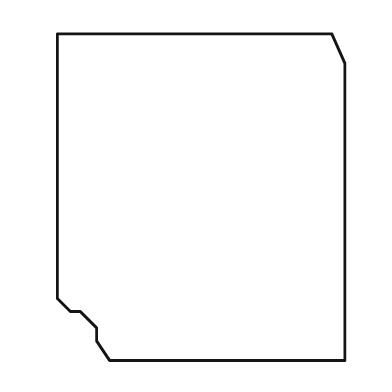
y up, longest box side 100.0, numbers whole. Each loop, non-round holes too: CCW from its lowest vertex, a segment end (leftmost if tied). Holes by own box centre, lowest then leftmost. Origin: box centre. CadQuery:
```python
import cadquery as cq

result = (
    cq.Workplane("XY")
    .moveTo(-28.0, -50.0)
    .lineTo(44.0, -50.0)
    .lineTo(44.0, 41.0)
    .lineTo(40.0, 50.0)
    .lineTo(-44.0, 50.0)
    .lineTo(-44.0, -31.0)
    .lineTo(-40.0, -35.0)
    .lineTo(-37.0, -35.0)
    .lineTo(-32.0, -40.0)
    .lineTo(-32.0, -44.0)
    .close()
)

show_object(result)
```